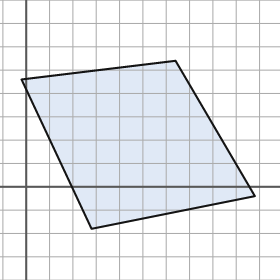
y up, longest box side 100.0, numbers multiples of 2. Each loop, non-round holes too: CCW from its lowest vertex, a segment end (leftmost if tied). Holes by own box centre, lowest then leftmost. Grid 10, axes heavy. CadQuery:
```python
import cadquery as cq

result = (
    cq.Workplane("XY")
    .moveTo(28.0, -18.0)
    .lineTo(98.0, -4.0)
    .lineTo(64.0, 54.0)
    .lineTo(-2.0, 46.0)
    .close()
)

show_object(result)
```